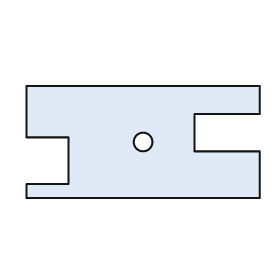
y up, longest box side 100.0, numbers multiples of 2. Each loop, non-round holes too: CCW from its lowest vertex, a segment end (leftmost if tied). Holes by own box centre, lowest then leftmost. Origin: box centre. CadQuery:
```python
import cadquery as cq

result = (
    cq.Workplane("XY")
    .moveTo(-50.0, -24.0)
    .lineTo(50.0, -24.0)
    .lineTo(50.0, -4.0)
    .lineTo(22.0, -4.0)
    .lineTo(22.0, 12.0)
    .lineTo(50.0, 12.0)
    .lineTo(50.0, 24.0)
    .lineTo(-50.0, 24.0)
    .lineTo(-50.0, 2.0)
    .lineTo(-32.0, 2.0)
    .lineTo(-32.0, -18.0)
    .lineTo(-50.0, -18.0)
    .close()
    .moveTo(0.0, 0.0)
    .circle(4.0)
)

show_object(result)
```